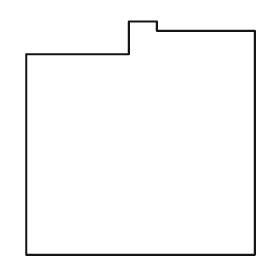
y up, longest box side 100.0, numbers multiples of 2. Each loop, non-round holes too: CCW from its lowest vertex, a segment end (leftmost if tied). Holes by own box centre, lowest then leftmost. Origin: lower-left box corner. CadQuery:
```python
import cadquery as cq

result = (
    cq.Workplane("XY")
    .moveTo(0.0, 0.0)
    .lineTo(98.0, 0.0)
    .lineTo(98.0, 96.0)
    .lineTo(56.0, 96.0)
    .lineTo(56.0, 100.0)
    .lineTo(44.0, 100.0)
    .lineTo(44.0, 86.0)
    .lineTo(0.0, 86.0)
    .close()
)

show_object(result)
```